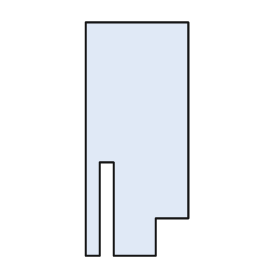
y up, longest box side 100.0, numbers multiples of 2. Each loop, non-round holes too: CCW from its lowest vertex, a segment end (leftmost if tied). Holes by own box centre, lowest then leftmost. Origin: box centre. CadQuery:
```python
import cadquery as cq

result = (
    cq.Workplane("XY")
    .moveTo(-22.0, -50.0)
    .lineTo(-16.0, -50.0)
    .lineTo(-16.0, -10.0)
    .lineTo(-10.0, -10.0)
    .lineTo(-10.0, -50.0)
    .lineTo(8.0, -50.0)
    .lineTo(8.0, -34.0)
    .lineTo(22.0, -34.0)
    .lineTo(22.0, 50.0)
    .lineTo(-22.0, 50.0)
    .close()
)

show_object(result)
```